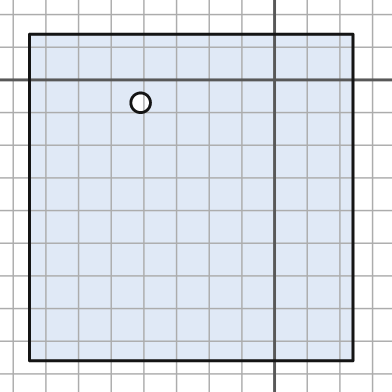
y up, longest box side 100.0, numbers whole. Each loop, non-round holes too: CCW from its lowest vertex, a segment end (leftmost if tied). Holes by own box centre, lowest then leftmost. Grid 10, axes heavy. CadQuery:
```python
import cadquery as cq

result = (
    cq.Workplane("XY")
    .moveTo(-75.0, -86.0)
    .lineTo(24.0, -86.0)
    .lineTo(24.0, 14.0)
    .lineTo(-75.0, 14.0)
    .close()
    .moveTo(-41.0, -7.0)
    .circle(3.0)
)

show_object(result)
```